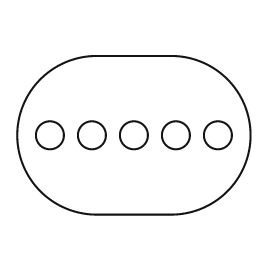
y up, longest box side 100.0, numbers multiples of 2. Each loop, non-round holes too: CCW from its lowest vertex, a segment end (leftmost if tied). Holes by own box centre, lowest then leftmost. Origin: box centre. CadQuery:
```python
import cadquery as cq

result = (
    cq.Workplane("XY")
    .moveTo(-16.0, -34.0)
    .lineTo(16.0, -34.0)
    .threePointArc((50.0, 0.0), (16.0, 34.0))
    .lineTo(-16.0, 34.0)
    .threePointArc((-50.0, 0.0), (-16.0, -34.0))
    .close()
    .moveTo(-36.0, 0.0)
    .circle(6.0)
    .moveTo(-18.0, 0.0)
    .circle(6.0)
    .moveTo(0.0, 0.0)
    .circle(6.0)
    .moveTo(18.0, 0.0)
    .circle(6.0)
    .moveTo(36.0, 0.0)
    .circle(6.0)
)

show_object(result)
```